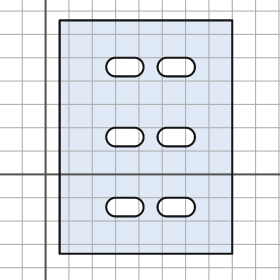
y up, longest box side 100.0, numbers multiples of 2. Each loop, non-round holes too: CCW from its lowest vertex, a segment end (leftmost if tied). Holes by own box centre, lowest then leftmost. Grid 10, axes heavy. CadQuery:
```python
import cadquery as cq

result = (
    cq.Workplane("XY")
    .moveTo(6.0, -34.0)
    .lineTo(80.0, -34.0)
    .lineTo(80.0, 66.0)
    .lineTo(6.0, 66.0)
    .close()
    .moveTo(30.0, -18.0)
    .lineTo(38.0, -18.0)
    .threePointArc((42.0, -14.0), (38.0, -10.0))
    .lineTo(30.0, -10.0)
    .threePointArc((26.0, -14.0), (30.0, -18.0))
    .close()
    .moveTo(52.0, -18.0)
    .lineTo(60.0, -18.0)
    .threePointArc((64.0, -14.0), (60.0, -10.0))
    .lineTo(52.0, -10.0)
    .threePointArc((48.0, -14.0), (52.0, -18.0))
    .close()
    .moveTo(30.0, 12.0)
    .lineTo(38.0, 12.0)
    .threePointArc((42.0, 16.0), (38.0, 20.0))
    .lineTo(30.0, 20.0)
    .threePointArc((26.0, 16.0), (30.0, 12.0))
    .close()
    .moveTo(52.0, 12.0)
    .lineTo(60.0, 12.0)
    .threePointArc((64.0, 16.0), (60.0, 20.0))
    .lineTo(52.0, 20.0)
    .threePointArc((48.0, 16.0), (52.0, 12.0))
    .close()
    .moveTo(30.0, 42.0)
    .lineTo(38.0, 42.0)
    .threePointArc((42.0, 46.0), (38.0, 50.0))
    .lineTo(30.0, 50.0)
    .threePointArc((26.0, 46.0), (30.0, 42.0))
    .close()
    .moveTo(52.0, 42.0)
    .lineTo(60.0, 42.0)
    .threePointArc((64.0, 46.0), (60.0, 50.0))
    .lineTo(52.0, 50.0)
    .threePointArc((48.0, 46.0), (52.0, 42.0))
    .close()
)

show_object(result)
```